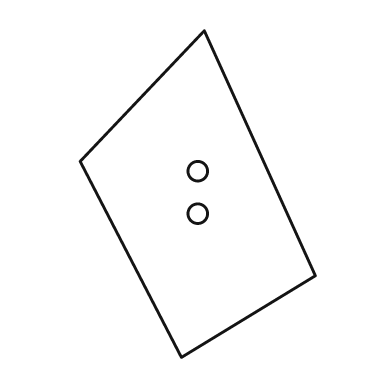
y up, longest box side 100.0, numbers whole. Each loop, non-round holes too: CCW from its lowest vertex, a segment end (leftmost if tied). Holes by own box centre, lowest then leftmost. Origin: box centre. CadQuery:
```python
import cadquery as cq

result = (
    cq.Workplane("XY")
    .moveTo(-5.0, -50.0)
    .lineTo(36.0, -25.0)
    .lineTo(2.0, 50.0)
    .lineTo(-36.0, 10.0)
    .close()
    .moveTo(0.0, -6.0)
    .circle(3.0)
    .moveTo(0.0, 7.0)
    .circle(3.0)
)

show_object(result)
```